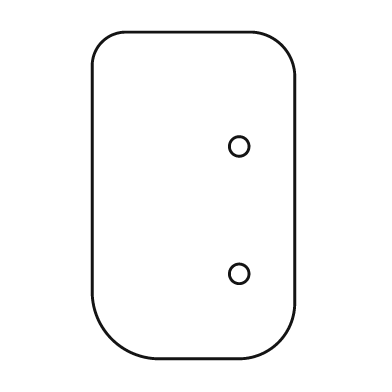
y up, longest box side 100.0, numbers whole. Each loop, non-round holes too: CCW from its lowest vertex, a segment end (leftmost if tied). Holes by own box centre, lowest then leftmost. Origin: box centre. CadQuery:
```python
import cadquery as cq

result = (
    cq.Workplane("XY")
    .moveTo(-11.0, -50.0)
    .lineTo(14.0, -50.0)
    .threePointArc((26.0, -45.0), (31.0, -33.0))
    .lineTo(31.0, 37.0)
    .threePointArc((27.0, 46.0), (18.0, 50.0))
    .lineTo(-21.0, 50.0)
    .threePointArc((-28.0, 47.0), (-31.0, 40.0))
    .lineTo(-31.0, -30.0)
    .threePointArc((-25.0, -44.0), (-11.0, -50.0))
    .close()
    .moveTo(14.0, -24.0)
    .circle(3.0)
    .moveTo(14.0, 15.0)
    .circle(3.0)
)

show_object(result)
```